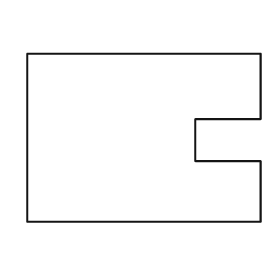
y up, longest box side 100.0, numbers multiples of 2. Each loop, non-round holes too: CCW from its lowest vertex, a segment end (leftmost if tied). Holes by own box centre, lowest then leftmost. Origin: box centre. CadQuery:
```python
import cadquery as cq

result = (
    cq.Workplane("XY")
    .moveTo(-50.0, -36.0)
    .lineTo(50.0, -36.0)
    .lineTo(50.0, -10.0)
    .lineTo(22.0, -10.0)
    .lineTo(22.0, 8.0)
    .lineTo(50.0, 8.0)
    .lineTo(50.0, 36.0)
    .lineTo(-50.0, 36.0)
    .close()
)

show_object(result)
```